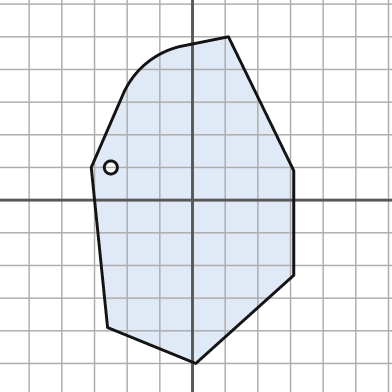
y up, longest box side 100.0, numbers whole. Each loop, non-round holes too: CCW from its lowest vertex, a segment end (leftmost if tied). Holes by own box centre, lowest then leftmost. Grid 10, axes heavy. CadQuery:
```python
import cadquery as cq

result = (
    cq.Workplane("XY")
    .moveTo(1.0, -50.0)
    .lineTo(31.0, -23.0)
    .lineTo(31.0, 9.0)
    .lineTo(11.0, 50.0)
    .lineTo(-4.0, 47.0)
    .threePointArc((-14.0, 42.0), (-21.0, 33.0))
    .lineTo(-31.0, 10.0)
    .lineTo(-26.0, -39.0)
    .close()
    .moveTo(-25.0, 10.0)
    .circle(2.0)
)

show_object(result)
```